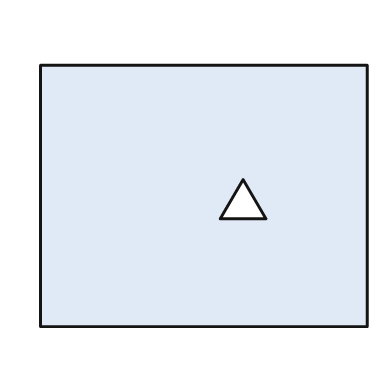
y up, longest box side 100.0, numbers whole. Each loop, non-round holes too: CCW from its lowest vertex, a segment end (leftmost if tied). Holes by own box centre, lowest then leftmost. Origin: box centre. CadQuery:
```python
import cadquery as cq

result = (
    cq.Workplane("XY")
    .moveTo(-50.0, -40.0)
    .lineTo(50.0, -40.0)
    .lineTo(50.0, 40.0)
    .lineTo(-50.0, 40.0)
    .close()
    .moveTo(5.0, -7.0)
    .lineTo(19.0, -7.0)
    .lineTo(12.0, 5.0)
    .close()
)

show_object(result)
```